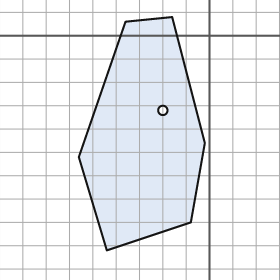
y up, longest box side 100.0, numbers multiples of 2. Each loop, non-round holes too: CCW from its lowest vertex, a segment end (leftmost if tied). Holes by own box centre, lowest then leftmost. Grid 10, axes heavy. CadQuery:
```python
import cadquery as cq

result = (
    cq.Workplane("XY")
    .moveTo(-44.0, -92.0)
    .lineTo(-8.0, -80.0)
    .lineTo(-2.0, -46.0)
    .lineTo(-16.0, 8.0)
    .lineTo(-36.0, 6.0)
    .lineTo(-56.0, -52.0)
    .close()
    .moveTo(-20.0, -32.0)
    .circle(2.0)
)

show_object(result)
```